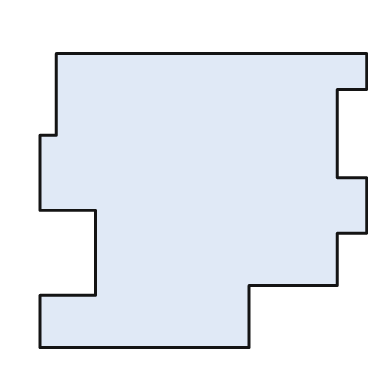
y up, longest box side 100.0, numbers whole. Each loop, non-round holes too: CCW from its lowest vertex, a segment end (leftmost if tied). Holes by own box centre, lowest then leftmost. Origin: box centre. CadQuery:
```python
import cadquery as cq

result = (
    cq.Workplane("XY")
    .moveTo(-50.0, -45.0)
    .lineTo(14.0, -45.0)
    .lineTo(14.0, -26.0)
    .lineTo(41.0, -26.0)
    .lineTo(41.0, -10.0)
    .lineTo(50.0, -10.0)
    .lineTo(50.0, 7.0)
    .lineTo(41.0, 7.0)
    .lineTo(41.0, 34.0)
    .lineTo(50.0, 34.0)
    .lineTo(50.0, 45.0)
    .lineTo(-45.0, 45.0)
    .lineTo(-45.0, 20.0)
    .lineTo(-50.0, 20.0)
    .lineTo(-50.0, -3.0)
    .lineTo(-33.0, -3.0)
    .lineTo(-33.0, -29.0)
    .lineTo(-50.0, -29.0)
    .close()
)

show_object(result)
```